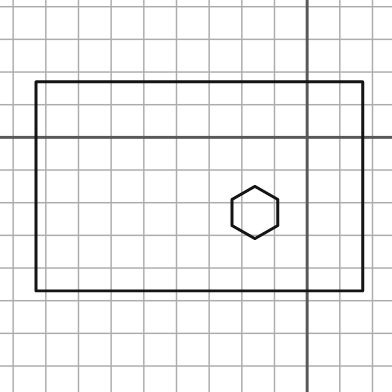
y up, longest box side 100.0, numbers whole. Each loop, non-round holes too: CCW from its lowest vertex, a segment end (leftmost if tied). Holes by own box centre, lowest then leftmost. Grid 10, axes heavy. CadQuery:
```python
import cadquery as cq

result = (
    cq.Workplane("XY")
    .moveTo(-83.0, -47.0)
    .lineTo(17.0, -47.0)
    .lineTo(17.0, 17.0)
    .lineTo(-83.0, 17.0)
    .close()
    .moveTo(-16.0, -31.0)
    .lineTo(-9.0, -27.0)
    .lineTo(-9.0, -19.0)
    .lineTo(-16.0, -15.0)
    .lineTo(-23.0, -19.0)
    .lineTo(-23.0, -27.0)
    .close()
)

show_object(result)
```